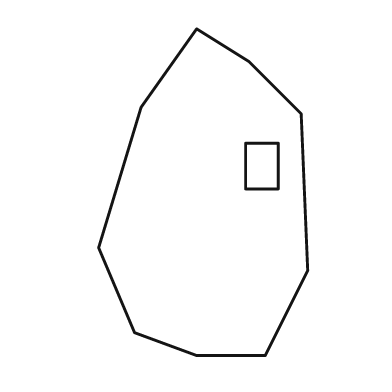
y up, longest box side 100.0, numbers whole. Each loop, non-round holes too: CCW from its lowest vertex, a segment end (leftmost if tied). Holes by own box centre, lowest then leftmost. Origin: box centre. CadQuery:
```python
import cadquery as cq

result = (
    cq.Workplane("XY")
    .moveTo(-2.0, -50.0)
    .lineTo(19.0, -50.0)
    .lineTo(32.0, -24.0)
    .lineTo(30.0, 24.0)
    .lineTo(14.0, 40.0)
    .lineTo(-2.0, 50.0)
    .lineTo(-19.0, 26.0)
    .lineTo(-32.0, -17.0)
    .lineTo(-21.0, -43.0)
    .close()
    .moveTo(13.0, 1.0)
    .lineTo(23.0, 1.0)
    .lineTo(23.0, 15.0)
    .lineTo(13.0, 15.0)
    .close()
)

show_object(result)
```